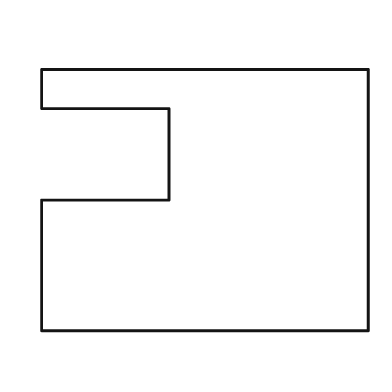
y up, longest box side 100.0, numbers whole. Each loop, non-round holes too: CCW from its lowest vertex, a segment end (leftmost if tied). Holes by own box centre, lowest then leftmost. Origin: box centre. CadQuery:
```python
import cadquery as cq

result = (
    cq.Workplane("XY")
    .moveTo(-50.0, -40.0)
    .lineTo(50.0, -40.0)
    .lineTo(50.0, 40.0)
    .lineTo(-50.0, 40.0)
    .lineTo(-50.0, 28.0)
    .lineTo(-11.0, 28.0)
    .lineTo(-11.0, 0.0)
    .lineTo(-50.0, 0.0)
    .close()
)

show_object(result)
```